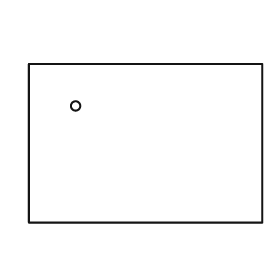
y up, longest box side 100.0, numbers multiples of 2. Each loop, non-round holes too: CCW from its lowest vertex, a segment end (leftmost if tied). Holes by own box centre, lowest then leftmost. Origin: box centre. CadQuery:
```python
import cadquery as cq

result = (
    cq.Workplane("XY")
    .moveTo(-50.0, -34.0)
    .lineTo(50.0, -34.0)
    .lineTo(50.0, 34.0)
    .lineTo(-50.0, 34.0)
    .close()
    .moveTo(-30.0, 16.0)
    .circle(2.0)
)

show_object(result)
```